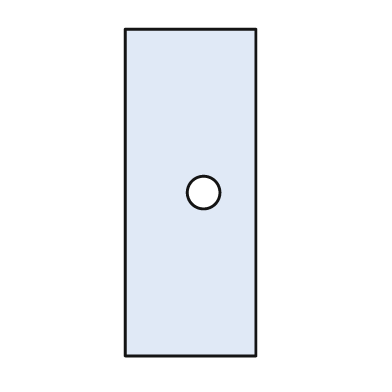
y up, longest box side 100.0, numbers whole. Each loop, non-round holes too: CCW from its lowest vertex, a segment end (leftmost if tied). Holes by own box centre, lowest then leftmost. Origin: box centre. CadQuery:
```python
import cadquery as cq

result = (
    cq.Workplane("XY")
    .moveTo(-20.0, -50.0)
    .lineTo(20.0, -50.0)
    .lineTo(20.0, 50.0)
    .lineTo(-20.0, 50.0)
    .close()
    .moveTo(4.0, 0.0)
    .circle(5.0)
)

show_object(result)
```